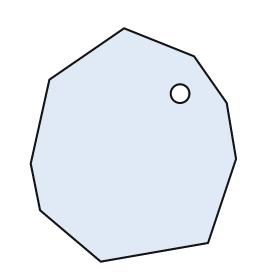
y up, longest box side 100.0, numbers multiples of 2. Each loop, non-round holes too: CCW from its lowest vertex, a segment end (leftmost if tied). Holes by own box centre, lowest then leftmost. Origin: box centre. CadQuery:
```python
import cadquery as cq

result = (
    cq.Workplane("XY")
    .moveTo(-14.0, -50.0)
    .lineTo(32.0, -42.0)
    .lineTo(44.0, -6.0)
    .lineTo(40.0, 18.0)
    .lineTo(26.0, 38.0)
    .lineTo(-4.0, 50.0)
    .lineTo(-36.0, 28.0)
    .lineTo(-44.0, -8.0)
    .lineTo(-40.0, -28.0)
    .close()
    .moveTo(20.0, 22.0)
    .circle(4.0)
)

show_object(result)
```